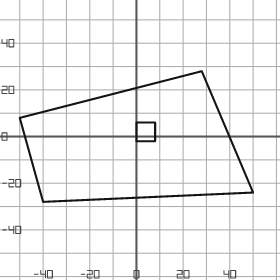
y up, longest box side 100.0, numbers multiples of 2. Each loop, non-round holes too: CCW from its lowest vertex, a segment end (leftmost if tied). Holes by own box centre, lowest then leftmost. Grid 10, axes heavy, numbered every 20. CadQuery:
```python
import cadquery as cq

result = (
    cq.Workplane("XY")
    .moveTo(-40.0, -28.0)
    .lineTo(50.0, -24.0)
    .lineTo(28.0, 28.0)
    .lineTo(-50.0, 8.0)
    .close()
    .moveTo(0.0, -2.0)
    .lineTo(8.0, -2.0)
    .lineTo(8.0, 6.0)
    .lineTo(0.0, 6.0)
    .close()
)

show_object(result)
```